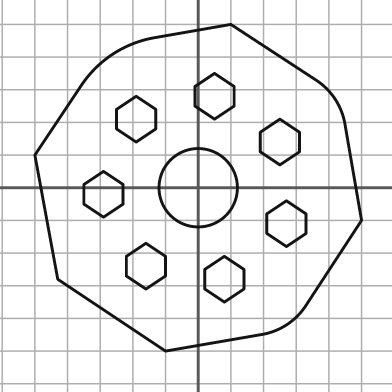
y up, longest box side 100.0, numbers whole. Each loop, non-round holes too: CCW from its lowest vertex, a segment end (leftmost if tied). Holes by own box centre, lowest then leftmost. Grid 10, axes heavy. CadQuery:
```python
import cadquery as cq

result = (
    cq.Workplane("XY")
    .moveTo(-10.0, -50.0)
    .lineTo(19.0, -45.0)
    .threePointArc((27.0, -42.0), (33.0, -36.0))
    .lineTo(50.0, -10.0)
    .lineTo(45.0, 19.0)
    .threePointArc((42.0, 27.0), (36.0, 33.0))
    .lineTo(10.0, 50.0)
    .lineTo(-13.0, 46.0)
    .threePointArc((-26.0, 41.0), (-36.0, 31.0))
    .lineTo(-50.0, 10.0)
    .lineTo(-43.0, -28.0)
    .close()
    .moveTo(8.0, -35.0)
    .lineTo(14.0, -31.0)
    .lineTo(14.0, -25.0)
    .lineTo(8.0, -21.0)
    .lineTo(2.0, -25.0)
    .lineTo(2.0, -31.0)
    .close()
    .moveTo(-16.0, -31.0)
    .lineTo(-10.0, -27.0)
    .lineTo(-10.0, -21.0)
    .lineTo(-16.0, -17.0)
    .lineTo(-22.0, -21.0)
    .lineTo(-22.0, -27.0)
    .close()
    .moveTo(27.0, -18.0)
    .lineTo(33.0, -14.0)
    .lineTo(33.0, -8.0)
    .lineTo(27.0, -4.0)
    .lineTo(21.0, -8.0)
    .lineTo(21.0, -14.0)
    .close()
    .moveTo(-29.0, -9.0)
    .lineTo(-23.0, -5.0)
    .lineTo(-23.0, 1.0)
    .lineTo(-29.0, 5.0)
    .lineTo(-35.0, 1.0)
    .lineTo(-35.0, -5.0)
    .close()
    .moveTo(0.0, 0.0)
    .circle(12.0)
    .moveTo(25.0, 7.0)
    .lineTo(31.0, 11.0)
    .lineTo(31.0, 17.0)
    .lineTo(25.0, 21.0)
    .lineTo(19.0, 17.0)
    .lineTo(19.0, 11.0)
    .close()
    .moveTo(-19.0, 14.0)
    .lineTo(-13.0, 18.0)
    .lineTo(-13.0, 24.0)
    .lineTo(-19.0, 28.0)
    .lineTo(-25.0, 24.0)
    .lineTo(-25.0, 18.0)
    .close()
    .moveTo(5.0, 21.0)
    .lineTo(11.0, 25.0)
    .lineTo(11.0, 31.0)
    .lineTo(5.0, 35.0)
    .lineTo(-1.0, 31.0)
    .lineTo(-1.0, 25.0)
    .close()
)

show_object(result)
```